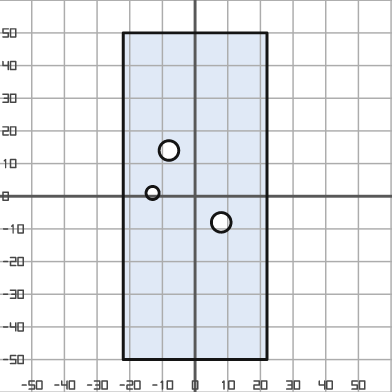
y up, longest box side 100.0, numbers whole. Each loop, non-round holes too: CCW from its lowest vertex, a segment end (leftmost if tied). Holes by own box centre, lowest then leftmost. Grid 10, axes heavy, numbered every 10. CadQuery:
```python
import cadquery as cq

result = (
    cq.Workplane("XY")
    .moveTo(-22.0, -50.0)
    .lineTo(22.0, -50.0)
    .lineTo(22.0, 50.0)
    .lineTo(-22.0, 50.0)
    .close()
    .moveTo(8.0, -8.0)
    .circle(3.0)
    .moveTo(-13.0, 1.0)
    .circle(2.0)
    .moveTo(-8.0, 14.0)
    .circle(3.0)
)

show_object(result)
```